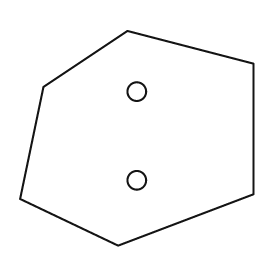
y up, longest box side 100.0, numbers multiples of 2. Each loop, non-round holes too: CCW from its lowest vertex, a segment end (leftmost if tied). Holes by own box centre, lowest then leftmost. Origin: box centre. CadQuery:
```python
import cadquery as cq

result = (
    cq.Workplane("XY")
    .moveTo(-8.0, -46.0)
    .lineTo(50.0, -24.0)
    .lineTo(50.0, 32.0)
    .lineTo(-4.0, 46.0)
    .lineTo(-40.0, 22.0)
    .lineTo(-50.0, -26.0)
    .close()
    .moveTo(0.0, -18.0)
    .circle(4.0)
    .moveTo(0.0, 20.0)
    .circle(4.0)
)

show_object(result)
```